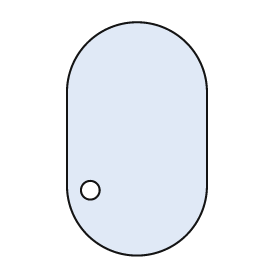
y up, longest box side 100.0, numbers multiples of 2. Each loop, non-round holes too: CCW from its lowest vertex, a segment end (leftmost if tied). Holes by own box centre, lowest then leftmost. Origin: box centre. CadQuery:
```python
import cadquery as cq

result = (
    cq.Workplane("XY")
    .moveTo(-30.0, -20.0)
    .threePointArc((0.0, -50.0), (30.0, -20.0))
    .lineTo(30.0, 20.0)
    .threePointArc((0.0, 50.0), (-30.0, 20.0))
    .close()
    .moveTo(-20.0, -22.0)
    .circle(4.0)
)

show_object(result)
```